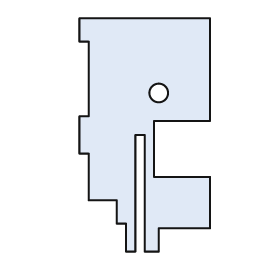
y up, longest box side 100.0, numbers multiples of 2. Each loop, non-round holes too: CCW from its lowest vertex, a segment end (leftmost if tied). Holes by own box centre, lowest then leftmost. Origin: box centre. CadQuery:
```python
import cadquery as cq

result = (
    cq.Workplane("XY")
    .moveTo(-8.0, -50.0)
    .lineTo(-4.0, -50.0)
    .lineTo(-4.0, 0.0)
    .lineTo(0.0, 0.0)
    .lineTo(0.0, -50.0)
    .lineTo(6.0, -50.0)
    .lineTo(6.0, -40.0)
    .lineTo(28.0, -40.0)
    .lineTo(28.0, -18.0)
    .lineTo(4.0, -18.0)
    .lineTo(4.0, 6.0)
    .lineTo(28.0, 6.0)
    .lineTo(28.0, 50.0)
    .lineTo(-28.0, 50.0)
    .lineTo(-28.0, 40.0)
    .lineTo(-24.0, 40.0)
    .lineTo(-24.0, 8.0)
    .lineTo(-28.0, 8.0)
    .lineTo(-28.0, -8.0)
    .lineTo(-24.0, -8.0)
    .lineTo(-24.0, -28.0)
    .lineTo(-12.0, -28.0)
    .lineTo(-12.0, -38.0)
    .lineTo(-8.0, -38.0)
    .close()
    .moveTo(6.0, 18.0)
    .circle(4.0)
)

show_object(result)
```